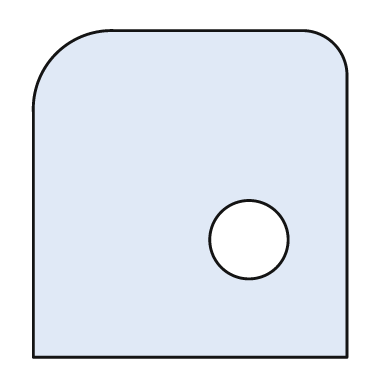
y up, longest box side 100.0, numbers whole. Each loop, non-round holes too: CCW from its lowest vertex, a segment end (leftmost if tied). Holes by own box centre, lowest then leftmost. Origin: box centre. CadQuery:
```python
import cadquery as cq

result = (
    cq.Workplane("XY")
    .moveTo(-48.0, -50.0)
    .lineTo(48.0, -50.0)
    .lineTo(48.0, 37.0)
    .threePointArc((44.0, 46.0), (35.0, 50.0))
    .lineTo(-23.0, 50.0)
    .threePointArc((-41.0, 43.0), (-48.0, 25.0))
    .close()
    .moveTo(18.0, -14.0)
    .circle(12.0)
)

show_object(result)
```